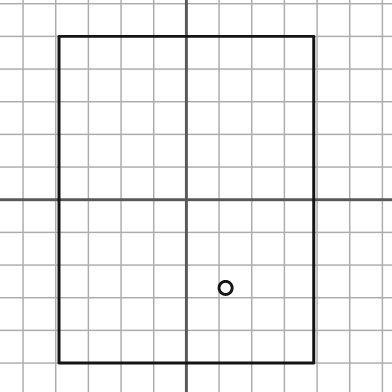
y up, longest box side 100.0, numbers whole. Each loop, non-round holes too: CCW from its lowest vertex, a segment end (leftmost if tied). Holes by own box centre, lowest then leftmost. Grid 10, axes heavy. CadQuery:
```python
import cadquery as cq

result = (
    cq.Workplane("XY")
    .moveTo(-39.0, -50.0)
    .lineTo(39.0, -50.0)
    .lineTo(39.0, 50.0)
    .lineTo(-39.0, 50.0)
    .close()
    .moveTo(12.0, -27.0)
    .circle(2.0)
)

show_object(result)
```